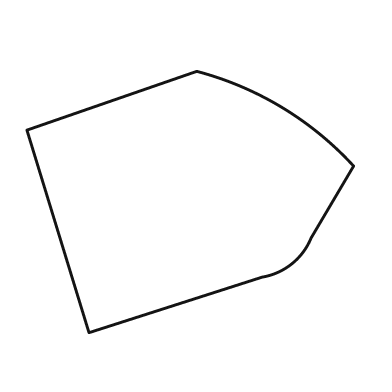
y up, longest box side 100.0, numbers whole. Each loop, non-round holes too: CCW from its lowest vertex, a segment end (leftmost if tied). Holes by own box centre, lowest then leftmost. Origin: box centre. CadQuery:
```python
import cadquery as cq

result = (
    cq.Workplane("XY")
    .moveTo(-31.0, -40.0)
    .lineTo(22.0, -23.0)
    .threePointArc((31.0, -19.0), (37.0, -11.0))
    .lineTo(50.0, 11.0)
    .threePointArc((28.0, 29.0), (2.0, 40.0))
    .lineTo(-50.0, 22.0)
    .close()
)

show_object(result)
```